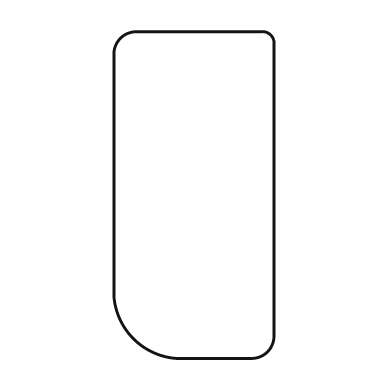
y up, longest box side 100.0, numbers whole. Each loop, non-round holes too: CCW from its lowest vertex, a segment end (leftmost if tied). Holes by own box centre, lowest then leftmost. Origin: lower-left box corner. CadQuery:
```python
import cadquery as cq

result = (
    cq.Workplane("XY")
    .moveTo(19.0, 0.0)
    .lineTo(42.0, 0.0)
    .threePointArc((47.0, 2.0), (49.0, 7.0))
    .lineTo(49.0, 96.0)
    .threePointArc((48.0, 99.0), (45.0, 100.0))
    .lineTo(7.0, 100.0)
    .threePointArc((2.0, 98.0), (0.0, 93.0))
    .lineTo(0.0, 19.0)
    .threePointArc((6.0, 6.0), (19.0, 0.0))
    .close()
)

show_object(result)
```